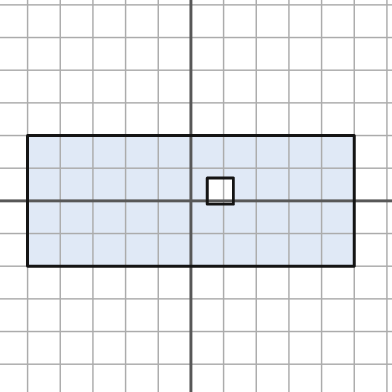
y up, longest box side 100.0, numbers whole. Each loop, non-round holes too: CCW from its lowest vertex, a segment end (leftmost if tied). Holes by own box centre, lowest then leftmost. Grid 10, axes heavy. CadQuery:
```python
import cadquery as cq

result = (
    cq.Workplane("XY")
    .moveTo(-50.0, -20.0)
    .lineTo(50.0, -20.0)
    .lineTo(50.0, 20.0)
    .lineTo(-50.0, 20.0)
    .close()
    .moveTo(5.0, -1.0)
    .lineTo(13.0, -1.0)
    .lineTo(13.0, 7.0)
    .lineTo(5.0, 7.0)
    .close()
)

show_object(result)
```